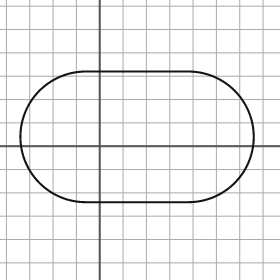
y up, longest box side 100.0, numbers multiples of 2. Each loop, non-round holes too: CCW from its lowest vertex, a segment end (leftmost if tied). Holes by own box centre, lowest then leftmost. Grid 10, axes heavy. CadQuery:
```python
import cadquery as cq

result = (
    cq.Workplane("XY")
    .moveTo(-6.0, -24.0)
    .lineTo(38.0, -24.0)
    .threePointArc((66.0, 4.0), (38.0, 32.0))
    .lineTo(-6.0, 32.0)
    .threePointArc((-34.0, 4.0), (-6.0, -24.0))
    .close()
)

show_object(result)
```